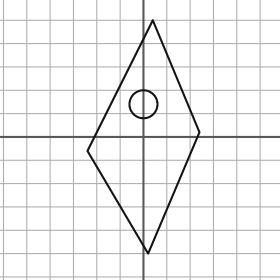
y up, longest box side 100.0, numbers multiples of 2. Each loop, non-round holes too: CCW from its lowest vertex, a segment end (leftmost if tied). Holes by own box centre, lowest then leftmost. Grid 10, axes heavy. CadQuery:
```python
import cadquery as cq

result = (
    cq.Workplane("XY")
    .moveTo(2.0, -50.0)
    .lineTo(24.0, 2.0)
    .lineTo(4.0, 50.0)
    .lineTo(-24.0, -6.0)
    .close()
    .moveTo(0.0, 14.0)
    .circle(6.0)
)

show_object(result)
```